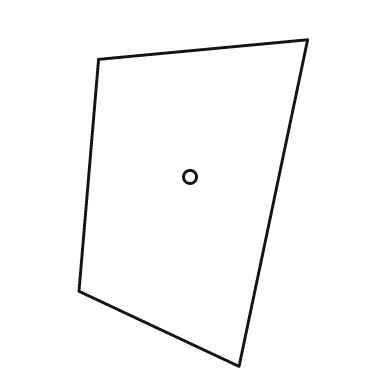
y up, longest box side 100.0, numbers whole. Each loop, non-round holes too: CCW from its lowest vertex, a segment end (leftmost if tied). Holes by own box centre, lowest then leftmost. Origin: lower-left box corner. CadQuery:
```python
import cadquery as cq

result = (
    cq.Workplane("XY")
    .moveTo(49.0, 0.0)
    .lineTo(70.0, 100.0)
    .lineTo(6.0, 94.0)
    .lineTo(0.0, 23.0)
    .close()
    .moveTo(34.0, 58.0)
    .circle(2.0)
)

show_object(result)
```